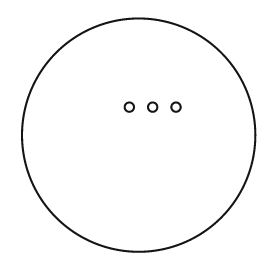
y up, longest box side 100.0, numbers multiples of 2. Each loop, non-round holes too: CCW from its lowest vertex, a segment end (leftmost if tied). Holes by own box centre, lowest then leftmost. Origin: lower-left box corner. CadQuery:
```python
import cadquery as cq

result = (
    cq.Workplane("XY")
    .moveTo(50.0, 50.0)
    .circle(50.0)
    .moveTo(46.0, 62.0)
    .circle(2.0)
    .moveTo(56.0, 62.0)
    .circle(2.0)
    .moveTo(66.0, 62.0)
    .circle(2.0)
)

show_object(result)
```